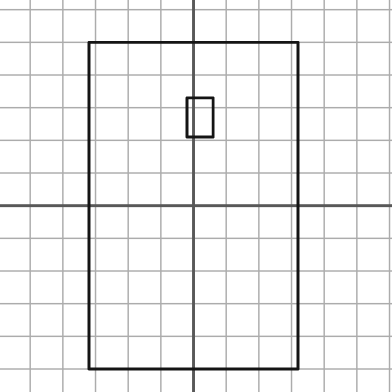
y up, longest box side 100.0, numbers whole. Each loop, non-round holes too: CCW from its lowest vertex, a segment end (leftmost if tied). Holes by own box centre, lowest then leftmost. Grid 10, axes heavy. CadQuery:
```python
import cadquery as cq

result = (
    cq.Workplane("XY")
    .moveTo(-32.0, -50.0)
    .lineTo(32.0, -50.0)
    .lineTo(32.0, 50.0)
    .lineTo(-32.0, 50.0)
    .close()
    .moveTo(-2.0, 21.0)
    .lineTo(6.0, 21.0)
    .lineTo(6.0, 33.0)
    .lineTo(-2.0, 33.0)
    .close()
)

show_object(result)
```